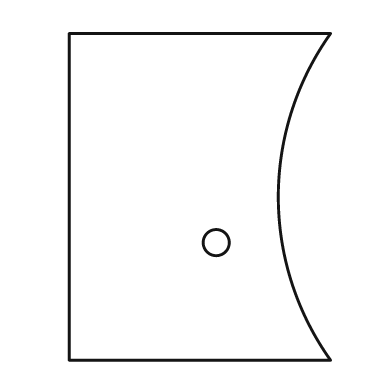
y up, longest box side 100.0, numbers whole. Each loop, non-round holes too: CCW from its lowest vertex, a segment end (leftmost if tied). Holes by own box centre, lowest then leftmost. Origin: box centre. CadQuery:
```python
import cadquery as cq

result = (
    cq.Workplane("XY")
    .moveTo(-40.0, -50.0)
    .lineTo(40.0, -50.0)
    .threePointArc((24.0, 0.0), (40.0, 50.0))
    .lineTo(-40.0, 50.0)
    .close()
    .moveTo(5.0, -14.0)
    .circle(4.0)
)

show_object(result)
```